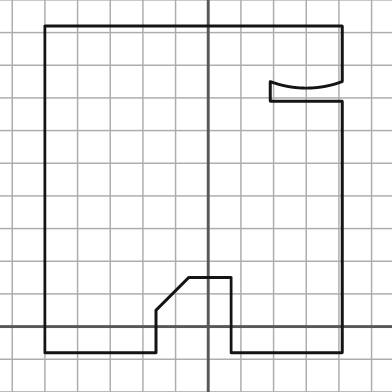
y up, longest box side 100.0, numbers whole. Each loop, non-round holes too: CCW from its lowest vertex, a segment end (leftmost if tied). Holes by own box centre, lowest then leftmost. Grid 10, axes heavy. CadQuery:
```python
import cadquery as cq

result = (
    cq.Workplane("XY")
    .moveTo(-50.0, -8.0)
    .lineTo(-16.0, -8.0)
    .lineTo(-16.0, 5.0)
    .lineTo(-6.0, 15.0)
    .lineTo(7.0, 15.0)
    .lineTo(7.0, -8.0)
    .lineTo(41.0, -8.0)
    .lineTo(41.0, 69.0)
    .lineTo(19.0, 69.0)
    .lineTo(19.0, 75.0)
    .threePointArc((30.0, 73.0), (41.0, 75.0))
    .lineTo(41.0, 92.0)
    .lineTo(-50.0, 92.0)
    .close()
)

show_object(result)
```